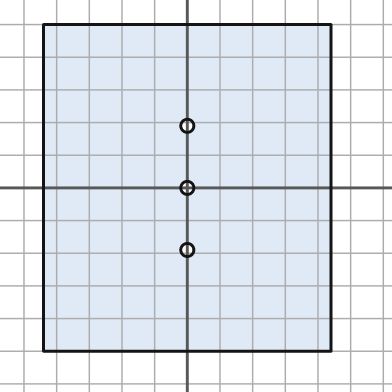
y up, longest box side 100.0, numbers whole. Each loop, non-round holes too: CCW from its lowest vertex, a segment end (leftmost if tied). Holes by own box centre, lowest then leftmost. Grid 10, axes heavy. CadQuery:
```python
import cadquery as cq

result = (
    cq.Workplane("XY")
    .moveTo(-44.0, -50.0)
    .lineTo(44.0, -50.0)
    .lineTo(44.0, 50.0)
    .lineTo(-44.0, 50.0)
    .close()
    .moveTo(0.0, -19.0)
    .circle(2.0)
    .moveTo(0.0, 0.0)
    .circle(2.0)
    .moveTo(0.0, 19.0)
    .circle(2.0)
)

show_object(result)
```